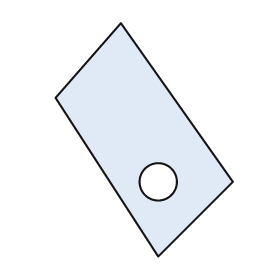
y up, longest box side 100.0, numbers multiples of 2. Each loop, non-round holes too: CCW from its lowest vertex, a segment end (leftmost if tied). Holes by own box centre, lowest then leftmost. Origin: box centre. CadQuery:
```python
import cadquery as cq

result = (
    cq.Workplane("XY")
    .moveTo(6.0, -50.0)
    .lineTo(38.0, -18.0)
    .lineTo(-10.0, 50.0)
    .lineTo(-38.0, 18.0)
    .close()
    .moveTo(6.0, -18.0)
    .circle(8.0)
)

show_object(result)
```